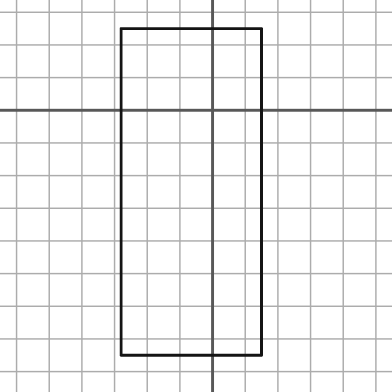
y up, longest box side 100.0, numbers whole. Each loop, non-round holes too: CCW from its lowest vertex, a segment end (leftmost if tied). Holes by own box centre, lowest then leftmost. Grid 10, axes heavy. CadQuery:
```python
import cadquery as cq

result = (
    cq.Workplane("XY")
    .moveTo(-28.0, -75.0)
    .lineTo(15.0, -75.0)
    .lineTo(15.0, 25.0)
    .lineTo(-28.0, 25.0)
    .close()
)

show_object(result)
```